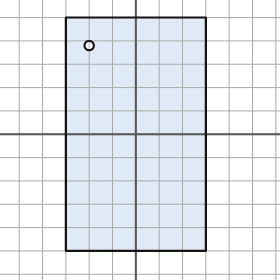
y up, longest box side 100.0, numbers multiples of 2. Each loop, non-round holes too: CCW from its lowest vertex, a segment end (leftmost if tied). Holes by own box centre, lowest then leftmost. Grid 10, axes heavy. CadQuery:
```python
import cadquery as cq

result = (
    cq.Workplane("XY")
    .moveTo(-30.0, -50.0)
    .lineTo(30.0, -50.0)
    .lineTo(30.0, 50.0)
    .lineTo(-30.0, 50.0)
    .close()
    .moveTo(-20.0, 38.0)
    .circle(2.0)
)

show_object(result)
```